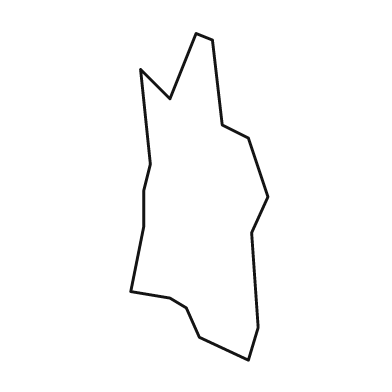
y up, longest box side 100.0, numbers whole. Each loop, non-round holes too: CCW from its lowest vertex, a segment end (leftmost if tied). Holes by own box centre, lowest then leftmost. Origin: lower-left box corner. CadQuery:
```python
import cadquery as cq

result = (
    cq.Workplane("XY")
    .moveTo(36.0, 0.0)
    .lineTo(39.0, 10.0)
    .lineTo(37.0, 39.0)
    .lineTo(42.0, 50.0)
    .lineTo(36.0, 68.0)
    .lineTo(28.0, 72.0)
    .lineTo(25.0, 98.0)
    .lineTo(20.0, 100.0)
    .lineTo(12.0, 80.0)
    .lineTo(3.0, 89.0)
    .lineTo(6.0, 60.0)
    .lineTo(4.0, 52.0)
    .lineTo(4.0, 41.0)
    .lineTo(0.0, 21.0)
    .lineTo(12.0, 19.0)
    .lineTo(17.0, 16.0)
    .lineTo(21.0, 7.0)
    .close()
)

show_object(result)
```